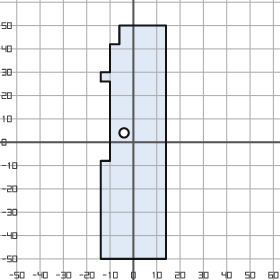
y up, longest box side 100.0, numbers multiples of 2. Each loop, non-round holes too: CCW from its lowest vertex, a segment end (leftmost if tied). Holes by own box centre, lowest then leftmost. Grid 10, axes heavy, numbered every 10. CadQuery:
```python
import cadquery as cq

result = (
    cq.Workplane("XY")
    .moveTo(-14.0, -50.0)
    .lineTo(14.0, -50.0)
    .lineTo(14.0, 50.0)
    .lineTo(-6.0, 50.0)
    .lineTo(-6.0, 42.0)
    .lineTo(-10.0, 42.0)
    .lineTo(-10.0, 30.0)
    .lineTo(-14.0, 30.0)
    .lineTo(-14.0, 26.0)
    .lineTo(-10.0, 26.0)
    .lineTo(-10.0, -8.0)
    .lineTo(-14.0, -8.0)
    .close()
    .moveTo(-4.0, 4.0)
    .circle(2.0)
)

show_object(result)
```